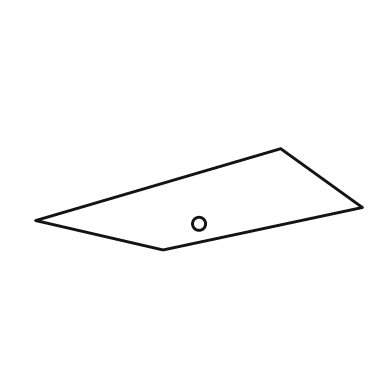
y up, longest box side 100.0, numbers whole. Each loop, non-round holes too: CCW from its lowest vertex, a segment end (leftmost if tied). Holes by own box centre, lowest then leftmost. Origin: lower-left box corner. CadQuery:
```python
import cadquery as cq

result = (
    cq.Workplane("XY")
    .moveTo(39.0, 0.0)
    .lineTo(100.0, 13.0)
    .lineTo(75.0, 31.0)
    .lineTo(0.0, 9.0)
    .close()
    .moveTo(50.0, 8.0)
    .circle(2.0)
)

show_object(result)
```